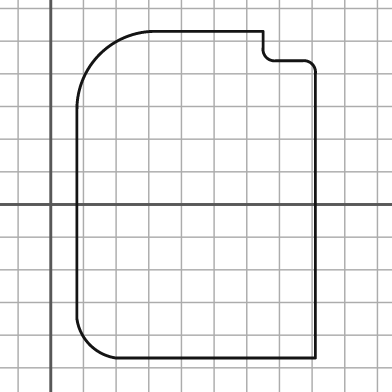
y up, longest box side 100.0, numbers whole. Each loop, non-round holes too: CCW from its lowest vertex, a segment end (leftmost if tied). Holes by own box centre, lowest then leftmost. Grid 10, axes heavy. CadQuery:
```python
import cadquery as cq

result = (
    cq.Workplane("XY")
    .moveTo(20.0, -47.0)
    .lineTo(81.0, -47.0)
    .lineTo(81.0, 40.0)
    .threePointArc((80.0, 43.0), (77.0, 44.0))
    .lineTo(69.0, 44.0)
    .threePointArc((66.0, 45.0), (65.0, 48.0))
    .lineTo(65.0, 53.0)
    .lineTo(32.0, 53.0)
    .threePointArc((15.0, 46.0), (8.0, 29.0))
    .lineTo(8.0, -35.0)
    .threePointArc((12.0, -43.0), (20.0, -47.0))
    .close()
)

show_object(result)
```